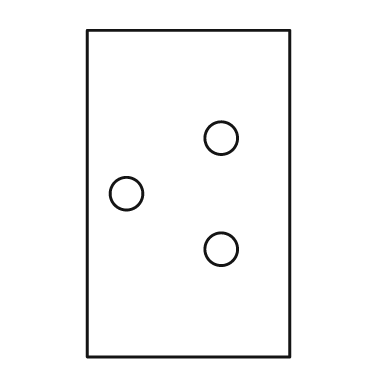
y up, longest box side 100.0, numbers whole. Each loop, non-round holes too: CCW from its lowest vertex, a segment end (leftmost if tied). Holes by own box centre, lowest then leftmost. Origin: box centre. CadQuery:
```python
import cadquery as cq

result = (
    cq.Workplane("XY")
    .moveTo(-31.0, -50.0)
    .lineTo(31.0, -50.0)
    .lineTo(31.0, 50.0)
    .lineTo(-31.0, 50.0)
    .close()
    .moveTo(10.0, -17.0)
    .circle(5.0)
    .moveTo(-19.0, 0.0)
    .circle(5.0)
    .moveTo(10.0, 17.0)
    .circle(5.0)
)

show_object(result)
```